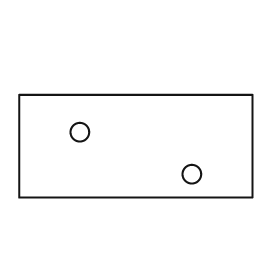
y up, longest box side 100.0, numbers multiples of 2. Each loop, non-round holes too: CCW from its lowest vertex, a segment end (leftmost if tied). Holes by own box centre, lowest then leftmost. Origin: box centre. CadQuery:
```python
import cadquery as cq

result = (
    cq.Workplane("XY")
    .moveTo(-50.0, -22.0)
    .lineTo(50.0, -22.0)
    .lineTo(50.0, 22.0)
    .lineTo(-50.0, 22.0)
    .close()
    .moveTo(24.0, -12.0)
    .circle(4.0)
    .moveTo(-24.0, 6.0)
    .circle(4.0)
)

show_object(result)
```